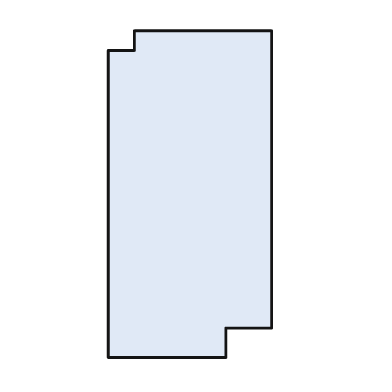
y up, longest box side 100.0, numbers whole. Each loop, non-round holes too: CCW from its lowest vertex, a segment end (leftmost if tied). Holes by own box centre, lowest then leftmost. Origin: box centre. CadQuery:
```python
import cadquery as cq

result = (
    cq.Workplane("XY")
    .moveTo(-25.0, -50.0)
    .lineTo(11.0, -50.0)
    .lineTo(11.0, -41.0)
    .lineTo(25.0, -41.0)
    .lineTo(25.0, 50.0)
    .lineTo(-17.0, 50.0)
    .lineTo(-17.0, 44.0)
    .lineTo(-25.0, 44.0)
    .close()
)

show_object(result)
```